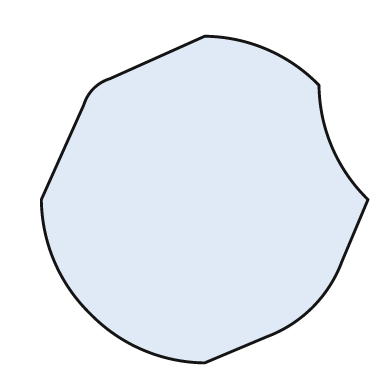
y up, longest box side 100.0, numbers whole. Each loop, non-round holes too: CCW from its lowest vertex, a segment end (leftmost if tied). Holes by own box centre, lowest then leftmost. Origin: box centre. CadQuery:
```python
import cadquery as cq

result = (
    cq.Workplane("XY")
    .moveTo(0.0, -50.0)
    .lineTo(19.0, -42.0)
    .threePointArc((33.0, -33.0), (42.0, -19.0))
    .lineTo(50.0, 0.0)
    .threePointArc((39.0, 16.0), (35.0, 35.0))
    .threePointArc((19.0, 46.0), (0.0, 50.0))
    .lineTo(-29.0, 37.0)
    .threePointArc((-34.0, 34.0), (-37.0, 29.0))
    .lineTo(-50.0, 0.0)
    .threePointArc((-46.0, -19.0), (-35.0, -35.0))
    .threePointArc((-19.0, -46.0), (0.0, -50.0))
    .close()
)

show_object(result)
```